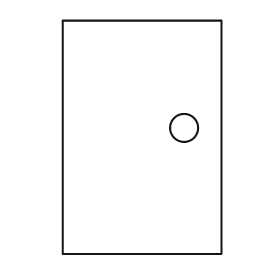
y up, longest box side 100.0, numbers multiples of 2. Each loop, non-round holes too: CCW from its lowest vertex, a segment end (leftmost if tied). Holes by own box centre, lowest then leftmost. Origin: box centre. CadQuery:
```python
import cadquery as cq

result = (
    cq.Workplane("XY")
    .moveTo(-34.0, -50.0)
    .lineTo(34.0, -50.0)
    .lineTo(34.0, 50.0)
    .lineTo(-34.0, 50.0)
    .close()
    .moveTo(18.0, 4.0)
    .circle(6.0)
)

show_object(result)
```